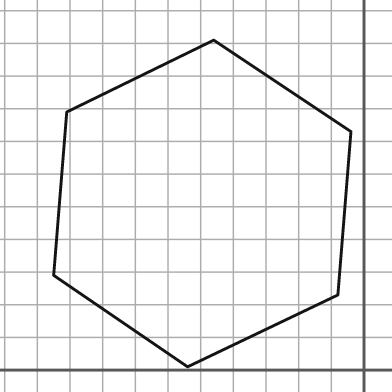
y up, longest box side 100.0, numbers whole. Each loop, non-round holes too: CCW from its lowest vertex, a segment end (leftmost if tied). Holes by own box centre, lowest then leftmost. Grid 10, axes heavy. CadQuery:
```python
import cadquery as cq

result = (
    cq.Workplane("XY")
    .moveTo(-54.0, 1.0)
    .lineTo(-8.0, 23.0)
    .lineTo(-4.0, 73.0)
    .lineTo(-46.0, 101.0)
    .lineTo(-91.0, 79.0)
    .lineTo(-95.0, 29.0)
    .close()
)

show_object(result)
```